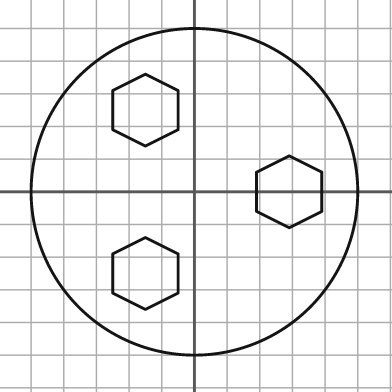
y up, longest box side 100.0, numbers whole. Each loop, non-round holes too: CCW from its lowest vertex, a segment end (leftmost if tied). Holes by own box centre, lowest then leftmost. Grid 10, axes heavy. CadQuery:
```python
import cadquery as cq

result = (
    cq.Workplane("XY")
    .moveTo(0.0, 0.0)
    .circle(50.0)
    .moveTo(-15.0, -36.0)
    .lineTo(-5.0, -31.0)
    .lineTo(-5.0, -19.0)
    .lineTo(-15.0, -14.0)
    .lineTo(-25.0, -19.0)
    .lineTo(-25.0, -31.0)
    .close()
    .moveTo(29.0, -11.0)
    .lineTo(39.0, -6.0)
    .lineTo(39.0, 6.0)
    .lineTo(29.0, 11.0)
    .lineTo(19.0, 6.0)
    .lineTo(19.0, -6.0)
    .close()
    .moveTo(-15.0, 14.0)
    .lineTo(-5.0, 19.0)
    .lineTo(-5.0, 31.0)
    .lineTo(-15.0, 36.0)
    .lineTo(-25.0, 31.0)
    .lineTo(-25.0, 19.0)
    .close()
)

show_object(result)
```